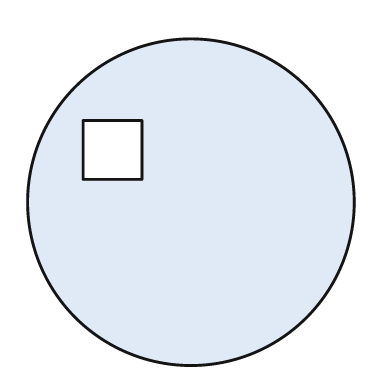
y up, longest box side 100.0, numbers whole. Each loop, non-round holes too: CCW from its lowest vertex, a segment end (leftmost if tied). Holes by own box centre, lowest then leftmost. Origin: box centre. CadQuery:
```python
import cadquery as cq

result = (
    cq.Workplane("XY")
    .moveTo(0.0, 0.0)
    .circle(50.0)
    .moveTo(-33.0, 7.0)
    .lineTo(-15.0, 7.0)
    .lineTo(-15.0, 25.0)
    .lineTo(-33.0, 25.0)
    .close()
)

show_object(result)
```